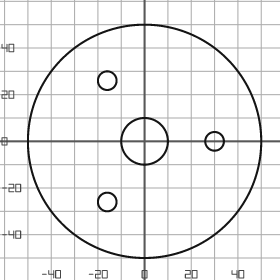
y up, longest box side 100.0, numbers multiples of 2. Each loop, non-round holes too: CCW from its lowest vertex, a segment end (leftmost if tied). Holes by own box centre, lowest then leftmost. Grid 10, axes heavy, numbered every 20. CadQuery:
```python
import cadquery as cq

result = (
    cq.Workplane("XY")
    .moveTo(0.0, 0.0)
    .circle(50.0)
    .moveTo(-16.0, -26.0)
    .circle(4.0)
    .moveTo(0.0, 0.0)
    .circle(10.0)
    .moveTo(30.0, 0.0)
    .circle(4.0)
    .moveTo(-16.0, 26.0)
    .circle(4.0)
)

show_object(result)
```